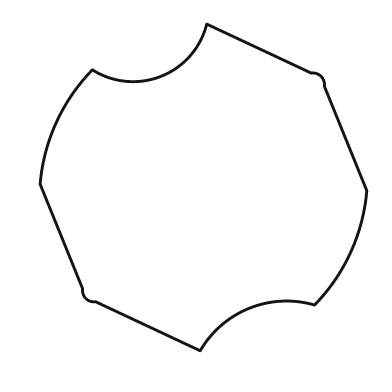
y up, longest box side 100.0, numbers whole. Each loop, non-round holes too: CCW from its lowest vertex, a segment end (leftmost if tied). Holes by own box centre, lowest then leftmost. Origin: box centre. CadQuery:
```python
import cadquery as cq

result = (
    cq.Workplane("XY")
    .moveTo(-1.0, -50.0)
    .threePointArc((14.0, -37.0), (34.0, -36.0))
    .threePointArc((45.0, -20.0), (50.0, -1.0))
    .lineTo(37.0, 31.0)
    .threePointArc((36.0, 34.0), (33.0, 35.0))
    .lineTo(1.0, 50.0)
    .threePointArc((-13.0, 34.0), (-34.0, 36.0))
    .threePointArc((-45.0, 20.0), (-50.0, 1.0))
    .lineTo(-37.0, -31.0)
    .threePointArc((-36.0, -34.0), (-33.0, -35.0))
    .close()
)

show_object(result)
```